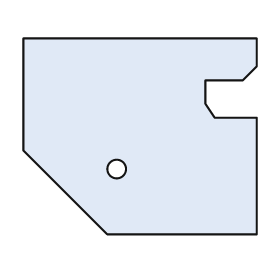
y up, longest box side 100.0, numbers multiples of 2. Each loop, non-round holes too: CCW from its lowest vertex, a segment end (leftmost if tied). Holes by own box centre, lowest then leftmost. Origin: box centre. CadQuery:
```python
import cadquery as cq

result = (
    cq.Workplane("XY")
    .moveTo(-14.0, -42.0)
    .lineTo(50.0, -42.0)
    .lineTo(50.0, 8.0)
    .lineTo(32.0, 8.0)
    .lineTo(28.0, 14.0)
    .lineTo(28.0, 24.0)
    .lineTo(44.0, 24.0)
    .lineTo(50.0, 30.0)
    .lineTo(50.0, 42.0)
    .lineTo(-50.0, 42.0)
    .lineTo(-50.0, -6.0)
    .close()
    .moveTo(-10.0, -14.0)
    .circle(4.0)
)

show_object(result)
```